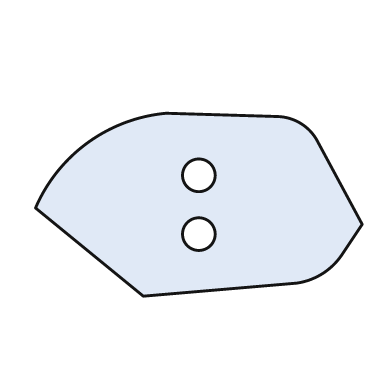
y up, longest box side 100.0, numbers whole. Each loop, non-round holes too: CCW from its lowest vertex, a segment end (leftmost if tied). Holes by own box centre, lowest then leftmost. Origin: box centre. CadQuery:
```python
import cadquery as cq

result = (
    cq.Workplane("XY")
    .moveTo(-17.0, -28.0)
    .lineTo(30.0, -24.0)
    .threePointArc((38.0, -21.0), (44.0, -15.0))
    .lineTo(50.0, -6.0)
    .lineTo(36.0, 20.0)
    .threePointArc((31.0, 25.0), (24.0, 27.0))
    .lineTo(-10.0, 28.0)
    .threePointArc((-34.0, 19.0), (-50.0, -1.0))
    .close()
    .moveTo(0.0, -9.0)
    .circle(5.0)
    .moveTo(0.0, 9.0)
    .circle(5.0)
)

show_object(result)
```